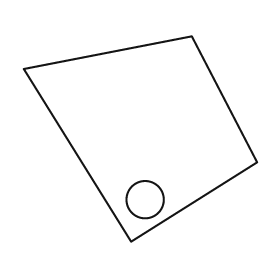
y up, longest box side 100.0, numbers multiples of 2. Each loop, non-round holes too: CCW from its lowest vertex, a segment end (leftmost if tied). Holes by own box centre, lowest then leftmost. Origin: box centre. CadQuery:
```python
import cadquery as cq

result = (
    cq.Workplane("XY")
    .moveTo(-4.0, -44.0)
    .lineTo(50.0, -10.0)
    .lineTo(22.0, 44.0)
    .lineTo(-50.0, 30.0)
    .close()
    .moveTo(2.0, -26.0)
    .circle(8.0)
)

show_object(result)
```